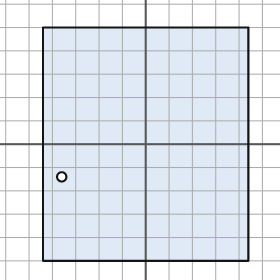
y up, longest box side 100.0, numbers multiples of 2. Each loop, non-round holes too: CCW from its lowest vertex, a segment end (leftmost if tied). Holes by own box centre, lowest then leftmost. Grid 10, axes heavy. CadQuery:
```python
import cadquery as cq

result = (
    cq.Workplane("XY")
    .moveTo(-44.0, -50.0)
    .lineTo(44.0, -50.0)
    .lineTo(44.0, 50.0)
    .lineTo(-44.0, 50.0)
    .close()
    .moveTo(-36.0, -14.0)
    .circle(2.0)
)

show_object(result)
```